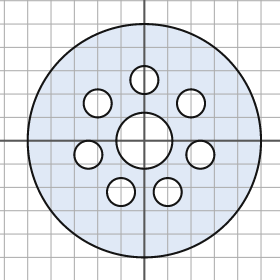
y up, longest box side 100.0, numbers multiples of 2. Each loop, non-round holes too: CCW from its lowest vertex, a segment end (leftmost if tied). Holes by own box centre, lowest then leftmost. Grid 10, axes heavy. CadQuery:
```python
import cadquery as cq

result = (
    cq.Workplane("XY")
    .moveTo(0.0, 0.0)
    .circle(50.0)
    .moveTo(-10.0, -22.0)
    .circle(6.0)
    .moveTo(10.0, -22.0)
    .circle(6.0)
    .moveTo(-24.0, -6.0)
    .circle(6.0)
    .moveTo(24.0, -6.0)
    .circle(6.0)
    .moveTo(0.0, 0.0)
    .circle(12.0)
    .moveTo(-20.0, 16.0)
    .circle(6.0)
    .moveTo(20.0, 16.0)
    .circle(6.0)
    .moveTo(0.0, 26.0)
    .circle(6.0)
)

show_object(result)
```